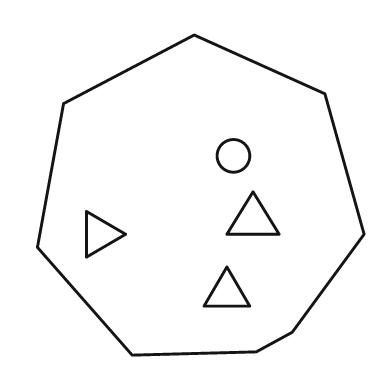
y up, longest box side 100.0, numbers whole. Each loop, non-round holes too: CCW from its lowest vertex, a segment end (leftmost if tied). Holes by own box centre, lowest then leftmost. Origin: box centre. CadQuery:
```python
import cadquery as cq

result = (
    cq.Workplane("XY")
    .moveTo(-21.0, -49.0)
    .lineTo(17.0, -48.0)
    .lineTo(28.0, -42.0)
    .lineTo(50.0, -12.0)
    .lineTo(38.0, 31.0)
    .lineTo(-2.0, 49.0)
    .lineTo(-42.0, 28.0)
    .lineTo(-50.0, -16.0)
    .close()
    .moveTo(1.0, -34.0)
    .lineTo(15.0, -34.0)
    .lineTo(8.0, -22.0)
    .close()
    .moveTo(-35.0, -19.0)
    .lineTo(-23.0, -12.0)
    .lineTo(-35.0, -5.0)
    .close()
    .moveTo(8.0, -12.0)
    .lineTo(24.0, -12.0)
    .lineTo(16.0, 1.0)
    .close()
    .moveTo(10.0, 12.0)
    .circle(5.0)
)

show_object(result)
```